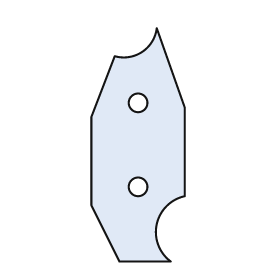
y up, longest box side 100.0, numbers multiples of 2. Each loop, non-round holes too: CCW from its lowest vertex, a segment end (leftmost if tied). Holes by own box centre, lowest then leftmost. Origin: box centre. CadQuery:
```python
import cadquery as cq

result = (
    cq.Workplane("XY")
    .moveTo(-8.0, -50.0)
    .lineTo(14.0, -50.0)
    .threePointArc((8.0, -34.0), (20.0, -22.0))
    .lineTo(20.0, 16.0)
    .lineTo(8.0, 50.0)
    .threePointArc((2.0, 40.0), (-10.0, 38.0))
    .lineTo(-20.0, 12.0)
    .lineTo(-20.0, -26.0)
    .close()
    .moveTo(0.0, -18.0)
    .circle(4.0)
    .moveTo(0.0, 18.0)
    .circle(4.0)
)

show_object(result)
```